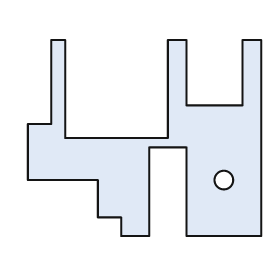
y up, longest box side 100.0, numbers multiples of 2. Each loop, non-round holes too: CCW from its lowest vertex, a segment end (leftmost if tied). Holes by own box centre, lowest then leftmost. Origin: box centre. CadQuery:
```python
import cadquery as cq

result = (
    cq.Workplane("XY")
    .moveTo(-10.0, -42.0)
    .lineTo(2.0, -42.0)
    .lineTo(2.0, -4.0)
    .lineTo(18.0, -4.0)
    .lineTo(18.0, -42.0)
    .lineTo(50.0, -42.0)
    .lineTo(50.0, 42.0)
    .lineTo(42.0, 42.0)
    .lineTo(42.0, 14.0)
    .lineTo(18.0, 14.0)
    .lineTo(18.0, 42.0)
    .lineTo(10.0, 42.0)
    .lineTo(10.0, 0.0)
    .lineTo(-34.0, 0.0)
    .lineTo(-34.0, 42.0)
    .lineTo(-40.0, 42.0)
    .lineTo(-40.0, 6.0)
    .lineTo(-50.0, 6.0)
    .lineTo(-50.0, -18.0)
    .lineTo(-20.0, -18.0)
    .lineTo(-20.0, -34.0)
    .lineTo(-10.0, -34.0)
    .close()
    .moveTo(34.0, -18.0)
    .circle(4.0)
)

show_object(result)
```